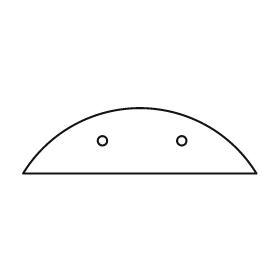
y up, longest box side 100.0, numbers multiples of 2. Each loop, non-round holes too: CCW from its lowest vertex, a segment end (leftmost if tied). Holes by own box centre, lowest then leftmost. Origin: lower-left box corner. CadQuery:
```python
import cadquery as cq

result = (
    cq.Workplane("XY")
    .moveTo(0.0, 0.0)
    .lineTo(100.0, 0.0)
    .threePointArc((50.0, 28.0), (0.0, 0.0))
    .close()
    .moveTo(34.0, 14.0)
    .circle(2.0)
    .moveTo(68.0, 14.0)
    .circle(2.0)
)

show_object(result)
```